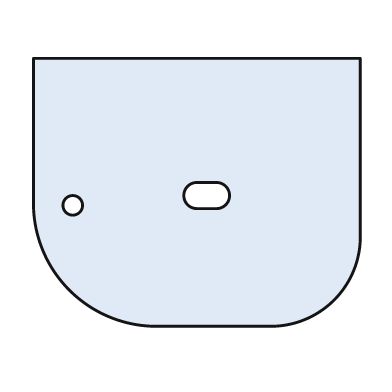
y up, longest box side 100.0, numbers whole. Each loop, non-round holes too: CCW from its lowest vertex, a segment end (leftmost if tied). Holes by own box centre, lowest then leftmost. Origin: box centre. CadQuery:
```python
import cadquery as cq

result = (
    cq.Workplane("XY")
    .moveTo(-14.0, -41.0)
    .lineTo(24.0, -41.0)
    .threePointArc((42.0, -33.0), (50.0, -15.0))
    .lineTo(50.0, 41.0)
    .lineTo(-50.0, 41.0)
    .lineTo(-50.0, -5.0)
    .threePointArc((-39.0, -30.0), (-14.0, -41.0))
    .close()
    .moveTo(-38.0, -4.0)
    .circle(3.0)
    .moveTo(0.0, -5.0)
    .lineTo(6.0, -5.0)
    .threePointArc((10.0, -1.0), (6.0, 3.0))
    .lineTo(0.0, 3.0)
    .threePointArc((-4.0, -1.0), (0.0, -5.0))
    .close()
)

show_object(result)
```